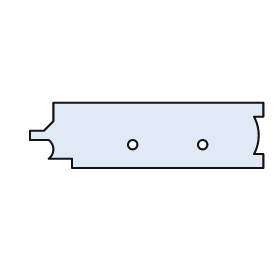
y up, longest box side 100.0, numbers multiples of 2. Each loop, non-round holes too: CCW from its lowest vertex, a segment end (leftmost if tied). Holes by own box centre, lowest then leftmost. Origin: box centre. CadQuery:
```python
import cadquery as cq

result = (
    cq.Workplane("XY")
    .moveTo(-32.0, -14.0)
    .lineTo(50.0, -14.0)
    .lineTo(50.0, -8.0)
    .lineTo(46.0, -8.0)
    .threePointArc((48.0, 0.0), (46.0, 8.0))
    .lineTo(50.0, 8.0)
    .lineTo(50.0, 14.0)
    .lineTo(-40.0, 14.0)
    .lineTo(-40.0, 6.0)
    .lineTo(-44.0, 2.0)
    .lineTo(-50.0, 2.0)
    .lineTo(-50.0, -2.0)
    .lineTo(-42.0, -2.0)
    .threePointArc((-40.0, -6.0), (-42.0, -10.0))
    .lineTo(-32.0, -10.0)
    .close()
    .moveTo(-6.0, -4.0)
    .circle(2.0)
    .moveTo(24.0, -4.0)
    .circle(2.0)
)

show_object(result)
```